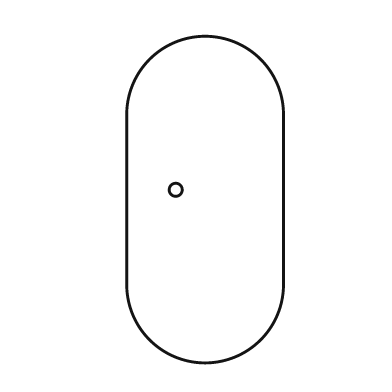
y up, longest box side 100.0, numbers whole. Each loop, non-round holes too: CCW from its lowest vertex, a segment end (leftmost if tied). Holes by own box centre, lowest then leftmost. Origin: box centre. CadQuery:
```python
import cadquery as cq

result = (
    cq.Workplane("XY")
    .moveTo(-24.0, -26.0)
    .threePointArc((0.0, -50.0), (24.0, -26.0))
    .lineTo(24.0, 26.0)
    .threePointArc((0.0, 50.0), (-24.0, 26.0))
    .close()
    .moveTo(-9.0, 3.0)
    .circle(2.0)
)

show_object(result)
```